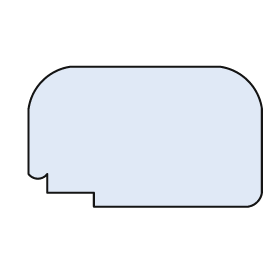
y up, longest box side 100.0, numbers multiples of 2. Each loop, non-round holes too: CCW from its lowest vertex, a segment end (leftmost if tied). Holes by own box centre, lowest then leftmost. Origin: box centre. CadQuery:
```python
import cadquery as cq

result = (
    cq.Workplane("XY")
    .moveTo(-22.0, -30.0)
    .lineTo(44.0, -30.0)
    .threePointArc((48.0, -28.0), (50.0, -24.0))
    .lineTo(50.0, 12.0)
    .threePointArc((44.0, 24.0), (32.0, 30.0))
    .lineTo(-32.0, 30.0)
    .threePointArc((-44.0, 24.0), (-50.0, 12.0))
    .lineTo(-50.0, -16.0)
    .threePointArc((-46.0, -18.0), (-42.0, -16.0))
    .lineTo(-42.0, -24.0)
    .lineTo(-22.0, -24.0)
    .close()
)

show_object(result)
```